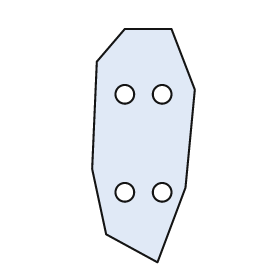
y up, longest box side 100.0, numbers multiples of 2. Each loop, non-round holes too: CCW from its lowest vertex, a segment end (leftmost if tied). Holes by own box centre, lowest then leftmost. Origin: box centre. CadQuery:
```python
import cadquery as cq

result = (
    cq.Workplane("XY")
    .moveTo(6.0, -50.0)
    .lineTo(18.0, -18.0)
    .lineTo(22.0, 24.0)
    .lineTo(12.0, 50.0)
    .lineTo(-8.0, 50.0)
    .lineTo(-20.0, 36.0)
    .lineTo(-22.0, -10.0)
    .lineTo(-16.0, -38.0)
    .close()
    .moveTo(-8.0, -20.0)
    .circle(4.0)
    .moveTo(8.0, -20.0)
    .circle(4.0)
    .moveTo(-8.0, 22.0)
    .circle(4.0)
    .moveTo(8.0, 22.0)
    .circle(4.0)
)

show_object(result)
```